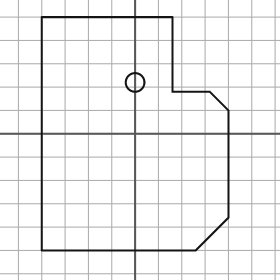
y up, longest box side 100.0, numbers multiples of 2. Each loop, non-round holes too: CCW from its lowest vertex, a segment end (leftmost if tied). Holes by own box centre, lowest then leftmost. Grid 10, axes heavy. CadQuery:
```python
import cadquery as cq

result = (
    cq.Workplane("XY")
    .moveTo(-40.0, -50.0)
    .lineTo(26.0, -50.0)
    .lineTo(40.0, -36.0)
    .lineTo(40.0, 10.0)
    .lineTo(32.0, 18.0)
    .lineTo(16.0, 18.0)
    .lineTo(16.0, 50.0)
    .lineTo(-40.0, 50.0)
    .close()
    .moveTo(0.0, 22.0)
    .circle(4.0)
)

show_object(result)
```